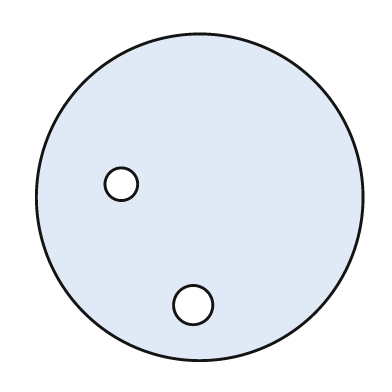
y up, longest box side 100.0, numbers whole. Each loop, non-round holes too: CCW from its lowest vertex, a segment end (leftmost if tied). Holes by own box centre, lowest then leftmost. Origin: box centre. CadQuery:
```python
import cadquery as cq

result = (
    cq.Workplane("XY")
    .moveTo(0.0, 0.0)
    .circle(50.0)
    .moveTo(-2.0, -33.0)
    .circle(6.0)
    .moveTo(-24.0, 4.0)
    .circle(5.0)
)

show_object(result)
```